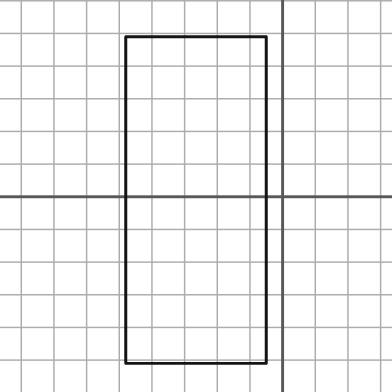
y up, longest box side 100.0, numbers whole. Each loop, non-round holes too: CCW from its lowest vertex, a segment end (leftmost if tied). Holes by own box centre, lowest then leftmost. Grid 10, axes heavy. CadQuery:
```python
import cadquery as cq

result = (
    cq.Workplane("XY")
    .moveTo(-48.0, -51.0)
    .lineTo(-5.0, -51.0)
    .lineTo(-5.0, 49.0)
    .lineTo(-48.0, 49.0)
    .close()
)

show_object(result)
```